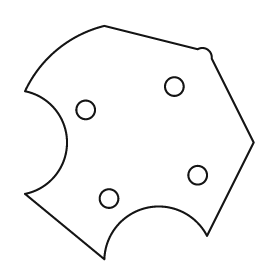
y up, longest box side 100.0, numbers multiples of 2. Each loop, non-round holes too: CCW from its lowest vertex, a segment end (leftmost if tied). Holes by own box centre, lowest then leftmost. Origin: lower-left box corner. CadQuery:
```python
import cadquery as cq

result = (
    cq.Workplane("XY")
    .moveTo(34.0, 0.0)
    .threePointArc((52.0, 22.0), (78.0, 10.0))
    .lineTo(98.0, 50.0)
    .lineTo(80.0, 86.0)
    .threePointArc((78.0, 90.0), (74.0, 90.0))
    .lineTo(34.0, 100.0)
    .threePointArc((14.0, 90.0), (0.0, 72.0))
    .threePointArc((18.0, 50.0), (0.0, 28.0))
    .close()
    .moveTo(36.0, 26.0)
    .circle(4.0)
    .moveTo(74.0, 36.0)
    .circle(4.0)
    .moveTo(26.0, 64.0)
    .circle(4.0)
    .moveTo(64.0, 74.0)
    .circle(4.0)
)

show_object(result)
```